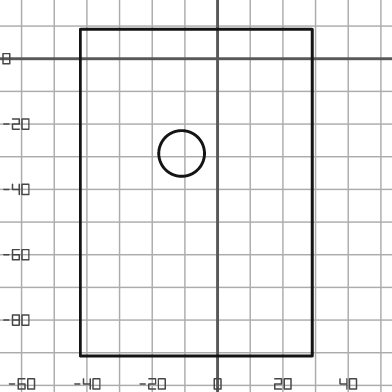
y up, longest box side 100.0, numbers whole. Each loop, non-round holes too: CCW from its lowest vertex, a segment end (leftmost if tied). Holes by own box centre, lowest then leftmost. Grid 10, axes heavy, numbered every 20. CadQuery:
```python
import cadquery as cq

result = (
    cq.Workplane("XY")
    .moveTo(-42.0, -91.0)
    .lineTo(29.0, -91.0)
    .lineTo(29.0, 9.0)
    .lineTo(-42.0, 9.0)
    .close()
    .moveTo(-11.0, -29.0)
    .circle(7.0)
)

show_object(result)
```